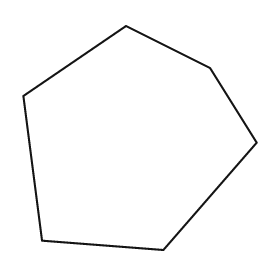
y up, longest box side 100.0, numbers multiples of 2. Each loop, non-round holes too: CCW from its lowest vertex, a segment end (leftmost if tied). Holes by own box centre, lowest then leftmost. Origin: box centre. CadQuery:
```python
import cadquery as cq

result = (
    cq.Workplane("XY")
    .moveTo(10.0, -48.0)
    .lineTo(50.0, -2.0)
    .lineTo(30.0, 30.0)
    .lineTo(-6.0, 48.0)
    .lineTo(-50.0, 18.0)
    .lineTo(-42.0, -44.0)
    .close()
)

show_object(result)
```